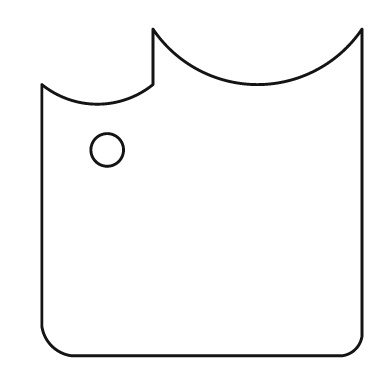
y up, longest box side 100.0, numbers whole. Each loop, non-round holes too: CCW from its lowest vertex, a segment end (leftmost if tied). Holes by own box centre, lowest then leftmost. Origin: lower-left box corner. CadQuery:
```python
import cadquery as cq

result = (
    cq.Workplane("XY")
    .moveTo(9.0, 0.0)
    .lineTo(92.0, 0.0)
    .threePointArc((96.0, 2.0), (98.0, 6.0))
    .lineTo(98.0, 100.0)
    .threePointArc((66.0, 83.0), (34.0, 100.0))
    .lineTo(34.0, 83.0)
    .threePointArc((17.0, 77.0), (0.0, 83.0))
    .lineTo(0.0, 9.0)
    .threePointArc((3.0, 3.0), (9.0, 0.0))
    .close()
    .moveTo(20.0, 63.0)
    .circle(5.0)
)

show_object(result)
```